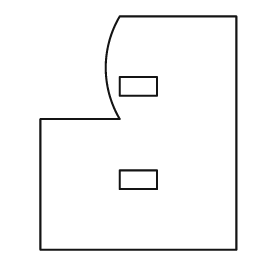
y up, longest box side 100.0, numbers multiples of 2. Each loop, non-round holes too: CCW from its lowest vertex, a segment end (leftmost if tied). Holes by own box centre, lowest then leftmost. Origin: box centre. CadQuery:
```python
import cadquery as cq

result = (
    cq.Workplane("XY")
    .moveTo(-42.0, -50.0)
    .lineTo(42.0, -50.0)
    .lineTo(42.0, 50.0)
    .lineTo(-8.0, 50.0)
    .threePointArc((-14.0, 28.0), (-8.0, 6.0))
    .lineTo(-42.0, 6.0)
    .close()
    .moveTo(-8.0, -24.0)
    .lineTo(8.0, -24.0)
    .lineTo(8.0, -16.0)
    .lineTo(-8.0, -16.0)
    .close()
    .moveTo(-8.0, 16.0)
    .lineTo(8.0, 16.0)
    .lineTo(8.0, 24.0)
    .lineTo(-8.0, 24.0)
    .close()
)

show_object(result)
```